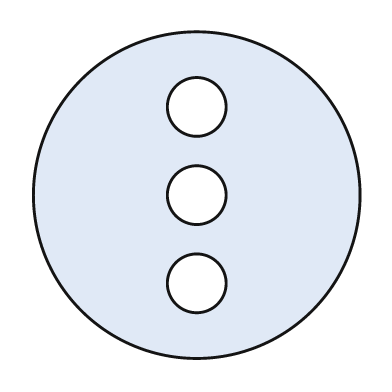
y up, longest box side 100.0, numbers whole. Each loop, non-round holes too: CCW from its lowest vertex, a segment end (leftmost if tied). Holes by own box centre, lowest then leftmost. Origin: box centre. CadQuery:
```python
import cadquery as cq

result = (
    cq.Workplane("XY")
    .moveTo(0.0, 0.0)
    .circle(50.0)
    .moveTo(0.0, -27.0)
    .circle(9.0)
    .moveTo(0.0, 0.0)
    .circle(9.0)
    .moveTo(0.0, 27.0)
    .circle(9.0)
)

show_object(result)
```